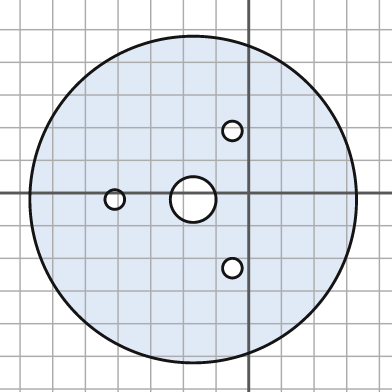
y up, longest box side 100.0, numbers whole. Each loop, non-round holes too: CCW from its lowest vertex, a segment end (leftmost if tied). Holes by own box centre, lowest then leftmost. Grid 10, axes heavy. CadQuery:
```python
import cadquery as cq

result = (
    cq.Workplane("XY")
    .moveTo(-17.0, -2.0)
    .circle(50.0)
    .moveTo(-5.0, -23.0)
    .circle(3.0)
    .moveTo(-41.0, -2.0)
    .circle(3.0)
    .moveTo(-17.0, -2.0)
    .circle(7.0)
    .moveTo(-5.0, 19.0)
    .circle(3.0)
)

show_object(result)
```